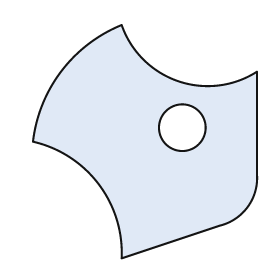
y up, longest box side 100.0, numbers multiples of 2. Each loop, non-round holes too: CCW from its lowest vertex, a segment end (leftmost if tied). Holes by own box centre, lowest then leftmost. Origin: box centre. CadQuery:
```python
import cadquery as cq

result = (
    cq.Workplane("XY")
    .moveTo(-10.0, -50.0)
    .lineTo(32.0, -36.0)
    .threePointArc((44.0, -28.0), (48.0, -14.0))
    .lineTo(48.0, 30.0)
    .threePointArc((14.0, 26.0), (-10.0, 50.0))
    .threePointArc((-36.0, 30.0), (-48.0, 0.0))
    .threePointArc((-20.0, -18.0), (-10.0, -50.0))
    .close()
    .moveTo(16.0, 6.0)
    .circle(10.0)
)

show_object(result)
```